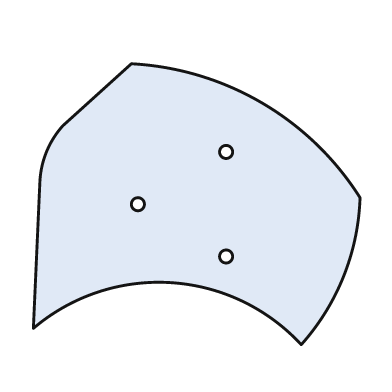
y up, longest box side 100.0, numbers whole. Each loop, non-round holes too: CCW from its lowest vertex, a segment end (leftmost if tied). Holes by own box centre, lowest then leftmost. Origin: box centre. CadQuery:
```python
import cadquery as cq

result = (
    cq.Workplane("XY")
    .moveTo(32.0, -43.0)
    .threePointArc((45.0, -22.0), (50.0, 2.0))
    .threePointArc((20.0, 31.0), (-20.0, 43.0))
    .lineTo(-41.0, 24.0)
    .threePointArc((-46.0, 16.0), (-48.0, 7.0))
    .lineTo(-50.0, -38.0)
    .threePointArc((-8.0, -24.0), (32.0, -43.0))
    .close()
    .moveTo(9.0, -16.0)
    .circle(2.0)
    .moveTo(-18.0, 0.0)
    .circle(2.0)
    .moveTo(9.0, 16.0)
    .circle(2.0)
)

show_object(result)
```